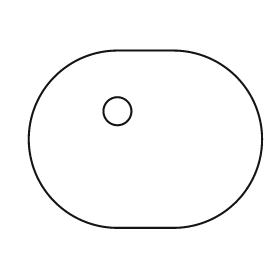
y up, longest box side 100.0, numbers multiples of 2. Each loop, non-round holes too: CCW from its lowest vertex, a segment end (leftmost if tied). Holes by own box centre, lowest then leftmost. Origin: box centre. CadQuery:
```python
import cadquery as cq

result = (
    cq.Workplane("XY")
    .moveTo(-12.0, -38.0)
    .lineTo(12.0, -38.0)
    .threePointArc((50.0, 0.0), (12.0, 38.0))
    .lineTo(-12.0, 38.0)
    .threePointArc((-50.0, 0.0), (-12.0, -38.0))
    .close()
    .moveTo(-12.0, 12.0)
    .circle(6.0)
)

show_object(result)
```